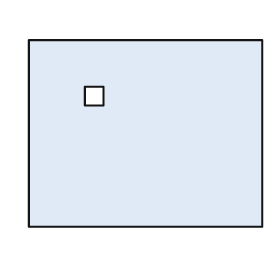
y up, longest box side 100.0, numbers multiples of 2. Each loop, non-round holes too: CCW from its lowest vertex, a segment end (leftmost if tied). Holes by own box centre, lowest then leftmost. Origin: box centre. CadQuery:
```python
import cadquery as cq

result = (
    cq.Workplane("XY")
    .moveTo(-50.0, -40.0)
    .lineTo(50.0, -40.0)
    .lineTo(50.0, 40.0)
    .lineTo(-50.0, 40.0)
    .close()
    .moveTo(-26.0, 12.0)
    .lineTo(-18.0, 12.0)
    .lineTo(-18.0, 20.0)
    .lineTo(-26.0, 20.0)
    .close()
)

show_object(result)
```